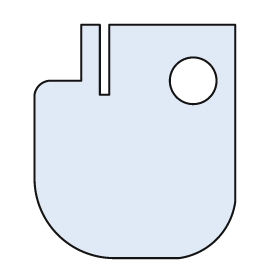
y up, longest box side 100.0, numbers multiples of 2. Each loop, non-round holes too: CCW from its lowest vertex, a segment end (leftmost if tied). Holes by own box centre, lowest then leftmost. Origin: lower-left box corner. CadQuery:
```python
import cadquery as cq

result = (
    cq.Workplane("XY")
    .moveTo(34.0, 0.0)
    .lineTo(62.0, 0.0)
    .threePointArc((78.0, 8.0), (86.0, 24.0))
    .lineTo(86.0, 100.0)
    .lineTo(32.0, 100.0)
    .lineTo(32.0, 70.0)
    .lineTo(28.0, 70.0)
    .lineTo(28.0, 100.0)
    .lineTo(20.0, 100.0)
    .lineTo(20.0, 76.0)
    .lineTo(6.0, 76.0)
    .threePointArc((2.0, 74.0), (0.0, 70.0))
    .lineTo(0.0, 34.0)
    .threePointArc((10.0, 10.0), (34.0, 0.0))
    .close()
    .moveTo(68.0, 76.0)
    .circle(10.0)
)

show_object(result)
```